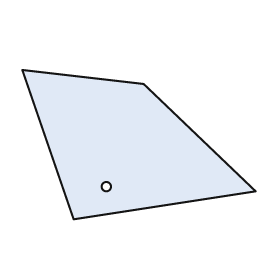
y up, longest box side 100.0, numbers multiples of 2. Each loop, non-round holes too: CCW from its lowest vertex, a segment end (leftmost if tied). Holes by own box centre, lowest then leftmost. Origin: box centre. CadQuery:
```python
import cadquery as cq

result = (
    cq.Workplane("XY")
    .moveTo(-28.0, -32.0)
    .lineTo(50.0, -20.0)
    .lineTo(2.0, 26.0)
    .lineTo(-50.0, 32.0)
    .close()
    .moveTo(-14.0, -18.0)
    .circle(2.0)
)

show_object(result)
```